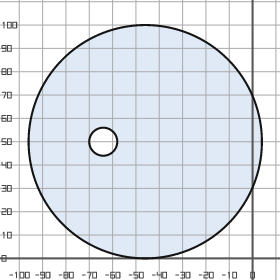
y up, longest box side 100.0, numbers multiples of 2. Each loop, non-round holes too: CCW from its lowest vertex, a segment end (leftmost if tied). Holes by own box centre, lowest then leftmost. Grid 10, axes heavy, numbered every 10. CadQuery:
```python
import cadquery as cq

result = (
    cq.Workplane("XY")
    .moveTo(-46.0, 50.0)
    .circle(50.0)
    .moveTo(-64.0, 50.0)
    .circle(6.0)
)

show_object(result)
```